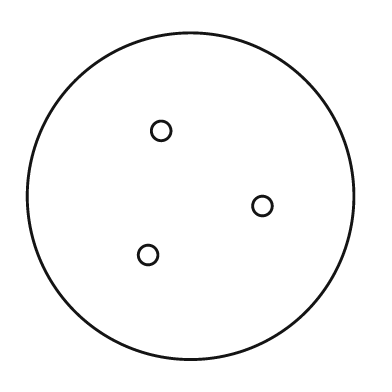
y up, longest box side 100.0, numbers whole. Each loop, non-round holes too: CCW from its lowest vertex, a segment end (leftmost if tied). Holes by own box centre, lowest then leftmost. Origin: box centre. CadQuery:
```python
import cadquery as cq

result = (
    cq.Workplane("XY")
    .moveTo(0.0, 0.0)
    .circle(50.0)
    .moveTo(-13.0, -18.0)
    .circle(3.0)
    .moveTo(22.0, -3.0)
    .circle(3.0)
    .moveTo(-9.0, 20.0)
    .circle(3.0)
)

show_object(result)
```